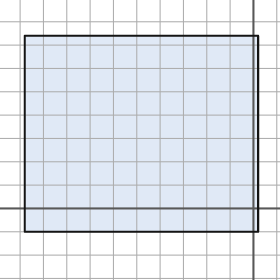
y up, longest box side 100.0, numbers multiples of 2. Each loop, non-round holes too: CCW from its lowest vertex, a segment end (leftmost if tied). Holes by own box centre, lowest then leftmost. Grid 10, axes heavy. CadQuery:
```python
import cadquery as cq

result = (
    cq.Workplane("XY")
    .moveTo(-98.0, -10.0)
    .lineTo(2.0, -10.0)
    .lineTo(2.0, 74.0)
    .lineTo(-98.0, 74.0)
    .close()
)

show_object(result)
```